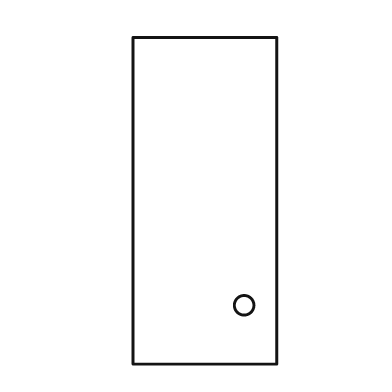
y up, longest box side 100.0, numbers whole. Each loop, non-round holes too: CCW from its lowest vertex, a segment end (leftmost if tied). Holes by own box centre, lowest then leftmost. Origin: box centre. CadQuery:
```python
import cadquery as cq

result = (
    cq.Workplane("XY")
    .moveTo(-22.0, -50.0)
    .lineTo(22.0, -50.0)
    .lineTo(22.0, 50.0)
    .lineTo(-22.0, 50.0)
    .close()
    .moveTo(12.0, -32.0)
    .circle(3.0)
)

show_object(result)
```